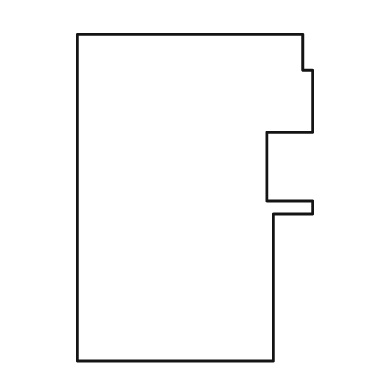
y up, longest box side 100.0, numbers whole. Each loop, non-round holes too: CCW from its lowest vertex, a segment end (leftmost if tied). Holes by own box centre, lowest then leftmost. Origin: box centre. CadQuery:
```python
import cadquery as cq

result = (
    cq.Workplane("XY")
    .moveTo(-36.0, -50.0)
    .lineTo(24.0, -50.0)
    .lineTo(24.0, -5.0)
    .lineTo(36.0, -5.0)
    .lineTo(36.0, -1.0)
    .lineTo(22.0, -1.0)
    .lineTo(22.0, 20.0)
    .lineTo(36.0, 20.0)
    .lineTo(36.0, 39.0)
    .lineTo(33.0, 39.0)
    .lineTo(33.0, 50.0)
    .lineTo(-36.0, 50.0)
    .close()
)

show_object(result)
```